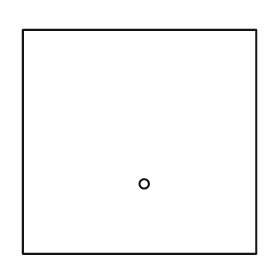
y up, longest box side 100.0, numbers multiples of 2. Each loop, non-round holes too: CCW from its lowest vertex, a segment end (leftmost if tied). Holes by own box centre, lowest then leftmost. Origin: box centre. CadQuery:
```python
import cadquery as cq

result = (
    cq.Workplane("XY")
    .moveTo(-50.0, -48.0)
    .lineTo(50.0, -48.0)
    .lineTo(50.0, 48.0)
    .lineTo(-50.0, 48.0)
    .close()
    .moveTo(2.0, -18.0)
    .circle(2.0)
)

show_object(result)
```